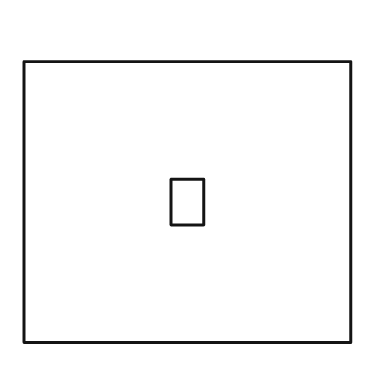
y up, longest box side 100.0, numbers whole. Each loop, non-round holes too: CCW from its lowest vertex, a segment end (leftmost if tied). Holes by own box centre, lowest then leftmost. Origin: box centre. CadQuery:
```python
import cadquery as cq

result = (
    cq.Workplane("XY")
    .moveTo(-50.0, -43.0)
    .lineTo(50.0, -43.0)
    .lineTo(50.0, 43.0)
    .lineTo(-50.0, 43.0)
    .close()
    .moveTo(-5.0, -7.0)
    .lineTo(5.0, -7.0)
    .lineTo(5.0, 7.0)
    .lineTo(-5.0, 7.0)
    .close()
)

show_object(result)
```